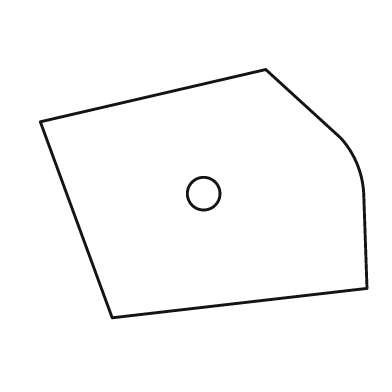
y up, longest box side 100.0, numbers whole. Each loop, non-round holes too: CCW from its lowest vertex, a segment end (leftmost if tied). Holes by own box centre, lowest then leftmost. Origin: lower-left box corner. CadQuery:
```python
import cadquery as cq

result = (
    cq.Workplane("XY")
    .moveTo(22.0, 0.0)
    .lineTo(100.0, 9.0)
    .lineTo(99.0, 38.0)
    .threePointArc((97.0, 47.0), (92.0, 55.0))
    .lineTo(69.0, 76.0)
    .lineTo(0.0, 60.0)
    .close()
    .moveTo(50.0, 38.0)
    .circle(5.0)
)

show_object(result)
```